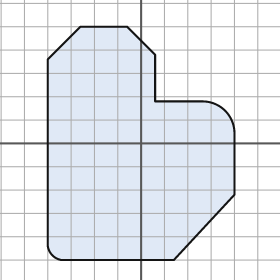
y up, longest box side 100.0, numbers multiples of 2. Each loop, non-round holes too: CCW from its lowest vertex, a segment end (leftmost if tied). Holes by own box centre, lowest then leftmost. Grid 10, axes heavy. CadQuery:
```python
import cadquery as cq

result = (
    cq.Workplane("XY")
    .moveTo(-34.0, -50.0)
    .lineTo(14.0, -50.0)
    .lineTo(40.0, -22.0)
    .lineTo(40.0, 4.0)
    .threePointArc((36.0, 14.0), (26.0, 18.0))
    .lineTo(6.0, 18.0)
    .lineTo(6.0, 38.0)
    .lineTo(-6.0, 50.0)
    .lineTo(-26.0, 50.0)
    .lineTo(-40.0, 36.0)
    .lineTo(-40.0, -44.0)
    .threePointArc((-38.0, -48.0), (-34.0, -50.0))
    .close()
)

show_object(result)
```